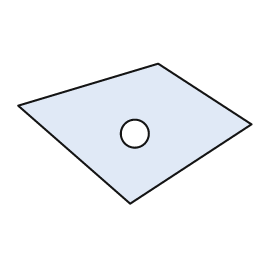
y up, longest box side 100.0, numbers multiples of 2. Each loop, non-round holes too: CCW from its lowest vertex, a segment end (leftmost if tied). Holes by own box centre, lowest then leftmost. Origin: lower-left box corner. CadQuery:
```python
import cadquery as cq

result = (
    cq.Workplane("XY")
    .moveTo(48.0, 0.0)
    .lineTo(100.0, 34.0)
    .lineTo(60.0, 60.0)
    .lineTo(0.0, 42.0)
    .close()
    .moveTo(50.0, 30.0)
    .circle(6.0)
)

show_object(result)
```